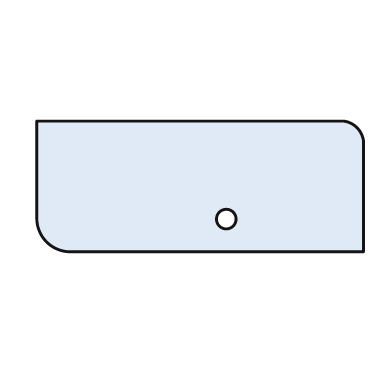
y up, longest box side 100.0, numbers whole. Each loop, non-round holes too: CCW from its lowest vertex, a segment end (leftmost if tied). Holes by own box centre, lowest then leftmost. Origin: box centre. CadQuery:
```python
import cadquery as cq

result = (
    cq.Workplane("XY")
    .moveTo(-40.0, -20.0)
    .lineTo(50.0, -20.0)
    .lineTo(50.0, 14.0)
    .threePointArc((48.0, 18.0), (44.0, 20.0))
    .lineTo(-50.0, 20.0)
    .lineTo(-50.0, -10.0)
    .threePointArc((-47.0, -17.0), (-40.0, -20.0))
    .close()
    .moveTo(8.0, -10.0)
    .circle(3.0)
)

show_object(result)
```